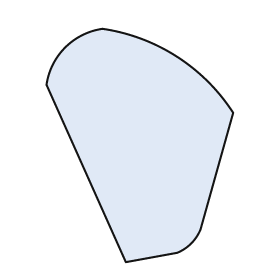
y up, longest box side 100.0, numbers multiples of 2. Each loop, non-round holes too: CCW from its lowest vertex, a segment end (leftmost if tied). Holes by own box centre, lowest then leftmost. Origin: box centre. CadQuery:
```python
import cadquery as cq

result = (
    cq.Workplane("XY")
    .moveTo(-6.0, -50.0)
    .lineTo(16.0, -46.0)
    .threePointArc((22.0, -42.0), (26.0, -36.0))
    .lineTo(40.0, 14.0)
    .threePointArc((16.0, 38.0), (-16.0, 50.0))
    .threePointArc((-32.0, 42.0), (-40.0, 26.0))
    .close()
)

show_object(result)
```